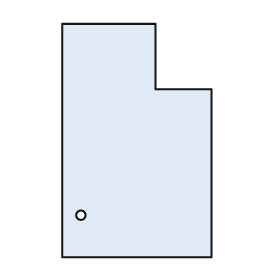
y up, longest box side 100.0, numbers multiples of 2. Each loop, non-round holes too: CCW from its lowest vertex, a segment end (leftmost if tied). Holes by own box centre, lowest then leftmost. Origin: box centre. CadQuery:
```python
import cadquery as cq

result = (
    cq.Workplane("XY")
    .moveTo(-32.0, -50.0)
    .lineTo(32.0, -50.0)
    .lineTo(32.0, 22.0)
    .lineTo(8.0, 22.0)
    .lineTo(8.0, 50.0)
    .lineTo(-32.0, 50.0)
    .close()
    .moveTo(-24.0, -32.0)
    .circle(2.0)
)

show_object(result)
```